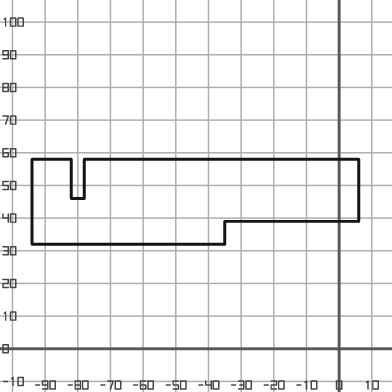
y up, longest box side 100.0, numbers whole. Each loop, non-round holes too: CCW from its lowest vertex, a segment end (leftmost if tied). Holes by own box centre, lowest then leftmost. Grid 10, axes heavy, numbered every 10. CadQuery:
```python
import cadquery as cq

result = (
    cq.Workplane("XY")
    .moveTo(-94.0, 32.0)
    .lineTo(-35.0, 32.0)
    .lineTo(-35.0, 39.0)
    .lineTo(6.0, 39.0)
    .lineTo(6.0, 58.0)
    .lineTo(-78.0, 58.0)
    .lineTo(-78.0, 46.0)
    .lineTo(-82.0, 46.0)
    .lineTo(-82.0, 58.0)
    .lineTo(-94.0, 58.0)
    .close()
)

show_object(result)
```